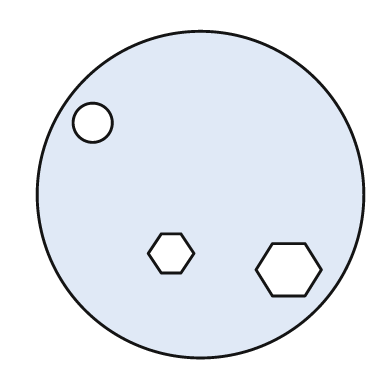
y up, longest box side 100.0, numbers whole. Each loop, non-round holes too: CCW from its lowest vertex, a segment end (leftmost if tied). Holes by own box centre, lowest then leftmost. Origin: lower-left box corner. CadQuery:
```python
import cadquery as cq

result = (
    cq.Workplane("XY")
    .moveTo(50.0, 50.0)
    .circle(50.0)
    .moveTo(72.0, 19.0)
    .lineTo(82.0, 19.0)
    .lineTo(87.0, 27.0)
    .lineTo(82.0, 35.0)
    .lineTo(72.0, 35.0)
    .lineTo(67.0, 27.0)
    .close()
    .moveTo(38.0, 26.0)
    .lineTo(44.0, 26.0)
    .lineTo(48.0, 32.0)
    .lineTo(44.0, 38.0)
    .lineTo(38.0, 38.0)
    .lineTo(34.0, 32.0)
    .close()
    .moveTo(17.0, 72.0)
    .circle(6.0)
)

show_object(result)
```